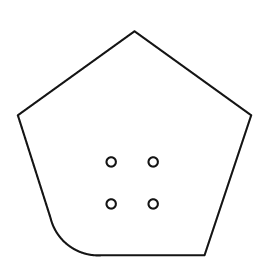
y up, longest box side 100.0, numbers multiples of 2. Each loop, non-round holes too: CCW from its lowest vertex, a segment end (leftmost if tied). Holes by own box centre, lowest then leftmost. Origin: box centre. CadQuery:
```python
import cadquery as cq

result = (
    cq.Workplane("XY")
    .moveTo(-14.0, -48.0)
    .lineTo(30.0, -48.0)
    .lineTo(50.0, 12.0)
    .lineTo(0.0, 48.0)
    .lineTo(-50.0, 12.0)
    .lineTo(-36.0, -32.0)
    .threePointArc((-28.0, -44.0), (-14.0, -48.0))
    .close()
    .moveTo(-10.0, -26.0)
    .circle(2.0)
    .moveTo(8.0, -26.0)
    .circle(2.0)
    .moveTo(-10.0, -8.0)
    .circle(2.0)
    .moveTo(8.0, -8.0)
    .circle(2.0)
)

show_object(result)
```